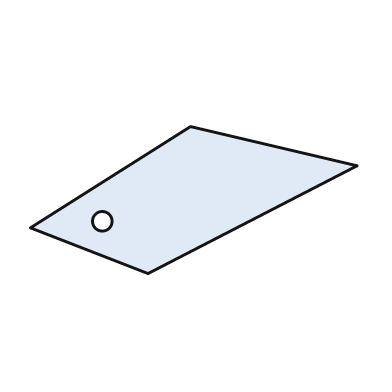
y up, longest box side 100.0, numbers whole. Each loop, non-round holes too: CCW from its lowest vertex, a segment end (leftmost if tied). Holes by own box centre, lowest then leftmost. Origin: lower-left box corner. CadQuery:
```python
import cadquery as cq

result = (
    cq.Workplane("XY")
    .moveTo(36.0, 0.0)
    .lineTo(100.0, 33.0)
    .lineTo(49.0, 45.0)
    .lineTo(0.0, 14.0)
    .close()
    .moveTo(22.0, 16.0)
    .circle(3.0)
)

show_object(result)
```